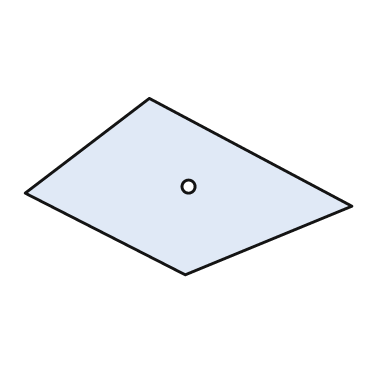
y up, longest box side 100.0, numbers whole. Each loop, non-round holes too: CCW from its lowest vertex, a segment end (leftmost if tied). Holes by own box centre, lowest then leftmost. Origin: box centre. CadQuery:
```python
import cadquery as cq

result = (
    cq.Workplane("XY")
    .moveTo(-1.0, -27.0)
    .lineTo(50.0, -6.0)
    .lineTo(-12.0, 27.0)
    .lineTo(-50.0, -2.0)
    .close()
    .moveTo(0.0, 0.0)
    .circle(2.0)
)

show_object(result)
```